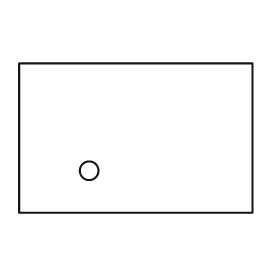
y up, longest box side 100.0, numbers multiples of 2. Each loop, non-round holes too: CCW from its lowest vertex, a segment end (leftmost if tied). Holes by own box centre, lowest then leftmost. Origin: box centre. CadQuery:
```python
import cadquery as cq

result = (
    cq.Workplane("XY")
    .moveTo(-50.0, -32.0)
    .lineTo(50.0, -32.0)
    .lineTo(50.0, 32.0)
    .lineTo(-50.0, 32.0)
    .close()
    .moveTo(-20.0, -14.0)
    .circle(4.0)
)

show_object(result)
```